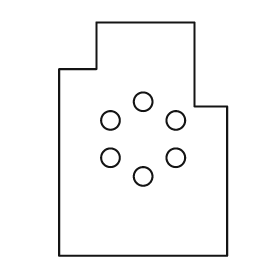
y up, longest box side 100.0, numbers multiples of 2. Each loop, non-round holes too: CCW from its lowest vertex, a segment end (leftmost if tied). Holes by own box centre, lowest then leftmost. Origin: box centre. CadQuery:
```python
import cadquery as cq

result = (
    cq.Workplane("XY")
    .moveTo(-36.0, -50.0)
    .lineTo(36.0, -50.0)
    .lineTo(36.0, 14.0)
    .lineTo(22.0, 14.0)
    .lineTo(22.0, 50.0)
    .lineTo(-20.0, 50.0)
    .lineTo(-20.0, 30.0)
    .lineTo(-36.0, 30.0)
    .close()
    .moveTo(0.0, -16.0)
    .circle(4.0)
    .moveTo(-14.0, -8.0)
    .circle(4.0)
    .moveTo(14.0, -8.0)
    .circle(4.0)
    .moveTo(-14.0, 8.0)
    .circle(4.0)
    .moveTo(14.0, 8.0)
    .circle(4.0)
    .moveTo(0.0, 16.0)
    .circle(4.0)
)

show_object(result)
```